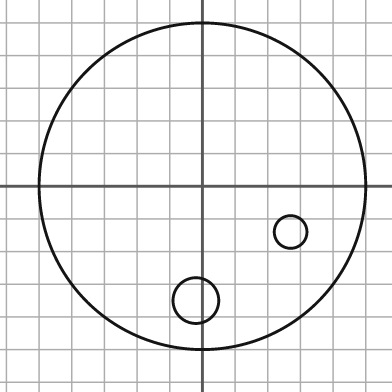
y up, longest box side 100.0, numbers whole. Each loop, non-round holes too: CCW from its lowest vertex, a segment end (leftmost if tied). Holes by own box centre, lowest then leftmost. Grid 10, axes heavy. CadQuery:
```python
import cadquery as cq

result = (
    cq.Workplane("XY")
    .moveTo(0.0, 0.0)
    .circle(50.0)
    .moveTo(-2.0, -35.0)
    .circle(7.0)
    .moveTo(27.0, -14.0)
    .circle(5.0)
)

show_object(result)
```